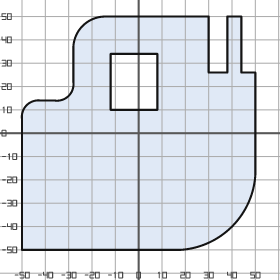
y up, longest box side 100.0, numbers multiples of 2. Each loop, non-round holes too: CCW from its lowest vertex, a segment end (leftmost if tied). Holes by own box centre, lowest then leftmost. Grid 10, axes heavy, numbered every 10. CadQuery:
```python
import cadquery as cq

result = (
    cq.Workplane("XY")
    .moveTo(-50.0, -50.0)
    .lineTo(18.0, -50.0)
    .threePointArc((40.0, -40.0), (50.0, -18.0))
    .lineTo(50.0, 26.0)
    .lineTo(44.0, 26.0)
    .lineTo(44.0, 50.0)
    .lineTo(38.0, 50.0)
    .lineTo(38.0, 26.0)
    .lineTo(30.0, 26.0)
    .lineTo(30.0, 50.0)
    .lineTo(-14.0, 50.0)
    .threePointArc((-24.0, 46.0), (-28.0, 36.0))
    .lineTo(-28.0, 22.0)
    .threePointArc((-30.0, 16.0), (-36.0, 14.0))
    .lineTo(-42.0, 14.0)
    .threePointArc((-48.0, 12.0), (-50.0, 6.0))
    .close()
    .moveTo(-12.0, 10.0)
    .lineTo(8.0, 10.0)
    .lineTo(8.0, 34.0)
    .lineTo(-12.0, 34.0)
    .close()
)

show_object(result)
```